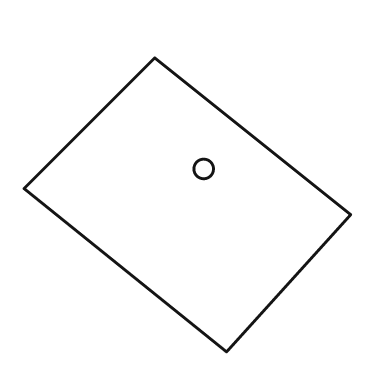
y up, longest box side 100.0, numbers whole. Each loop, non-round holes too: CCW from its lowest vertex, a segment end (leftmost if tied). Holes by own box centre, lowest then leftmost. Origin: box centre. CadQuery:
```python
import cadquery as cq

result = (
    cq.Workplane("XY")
    .moveTo(12.0, -45.0)
    .lineTo(50.0, -3.0)
    .lineTo(-10.0, 45.0)
    .lineTo(-50.0, 5.0)
    .close()
    .moveTo(5.0, 11.0)
    .circle(3.0)
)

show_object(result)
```